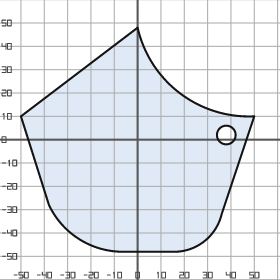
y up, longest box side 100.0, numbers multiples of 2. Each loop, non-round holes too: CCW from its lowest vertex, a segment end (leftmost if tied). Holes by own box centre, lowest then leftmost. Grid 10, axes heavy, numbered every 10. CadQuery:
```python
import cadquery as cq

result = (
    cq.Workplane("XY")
    .moveTo(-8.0, -48.0)
    .lineTo(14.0, -48.0)
    .threePointArc((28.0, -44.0), (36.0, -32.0))
    .lineTo(50.0, 10.0)
    .threePointArc((18.0, 20.0), (0.0, 48.0))
    .lineTo(-50.0, 10.0)
    .lineTo(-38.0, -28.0)
    .threePointArc((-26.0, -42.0), (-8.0, -48.0))
    .close()
    .moveTo(38.0, 2.0)
    .circle(4.0)
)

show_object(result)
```